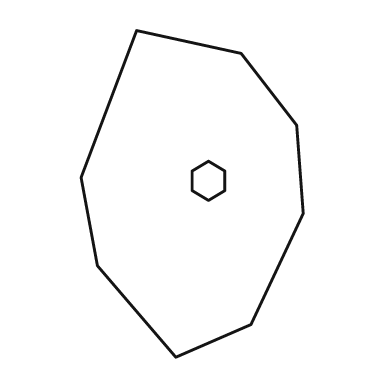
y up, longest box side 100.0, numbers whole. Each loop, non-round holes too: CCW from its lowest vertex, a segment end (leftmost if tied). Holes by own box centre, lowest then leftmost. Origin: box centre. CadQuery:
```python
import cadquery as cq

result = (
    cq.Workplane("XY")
    .moveTo(-5.0, -50.0)
    .lineTo(18.0, -40.0)
    .lineTo(34.0, -6.0)
    .lineTo(32.0, 21.0)
    .lineTo(15.0, 43.0)
    .lineTo(-17.0, 50.0)
    .lineTo(-34.0, 5.0)
    .lineTo(-29.0, -22.0)
    .close()
    .moveTo(5.0, -2.0)
    .lineTo(10.0, 1.0)
    .lineTo(10.0, 7.0)
    .lineTo(5.0, 10.0)
    .lineTo(0.0, 7.0)
    .lineTo(0.0, 1.0)
    .close()
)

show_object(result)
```